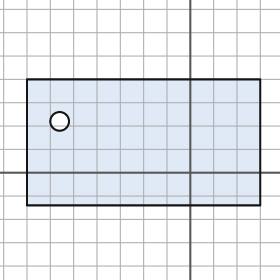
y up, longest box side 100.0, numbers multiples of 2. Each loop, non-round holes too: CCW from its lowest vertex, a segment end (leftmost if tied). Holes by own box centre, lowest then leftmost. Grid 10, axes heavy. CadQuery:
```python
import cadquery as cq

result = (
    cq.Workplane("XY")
    .moveTo(-70.0, -14.0)
    .lineTo(30.0, -14.0)
    .lineTo(30.0, 40.0)
    .lineTo(-70.0, 40.0)
    .close()
    .moveTo(-56.0, 22.0)
    .circle(4.0)
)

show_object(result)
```